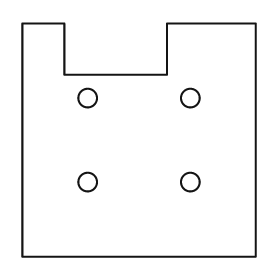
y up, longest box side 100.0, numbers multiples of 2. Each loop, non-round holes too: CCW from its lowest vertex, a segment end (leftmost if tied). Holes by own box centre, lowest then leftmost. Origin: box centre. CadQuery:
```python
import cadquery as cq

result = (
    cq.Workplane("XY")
    .moveTo(-50.0, -50.0)
    .lineTo(50.0, -50.0)
    .lineTo(50.0, 50.0)
    .lineTo(12.0, 50.0)
    .lineTo(12.0, 28.0)
    .lineTo(-32.0, 28.0)
    .lineTo(-32.0, 50.0)
    .lineTo(-50.0, 50.0)
    .close()
    .moveTo(-22.0, -18.0)
    .circle(4.0)
    .moveTo(22.0, -18.0)
    .circle(4.0)
    .moveTo(-22.0, 18.0)
    .circle(4.0)
    .moveTo(22.0, 18.0)
    .circle(4.0)
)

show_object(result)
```